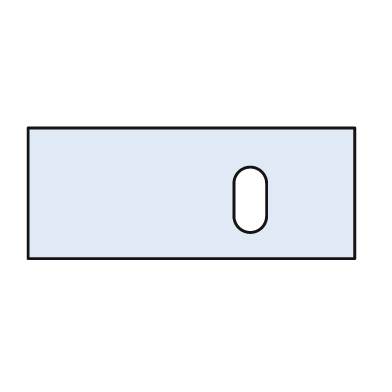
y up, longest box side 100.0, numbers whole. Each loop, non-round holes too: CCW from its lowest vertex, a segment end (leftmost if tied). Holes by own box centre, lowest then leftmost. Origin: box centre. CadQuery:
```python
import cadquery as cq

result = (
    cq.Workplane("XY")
    .moveTo(-50.0, -20.0)
    .lineTo(50.0, -20.0)
    .lineTo(50.0, 20.0)
    .lineTo(-50.0, 20.0)
    .close()
    .moveTo(13.0, -7.0)
    .threePointArc((18.0, -12.0), (23.0, -7.0))
    .lineTo(23.0, 3.0)
    .threePointArc((18.0, 8.0), (13.0, 3.0))
    .close()
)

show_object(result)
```